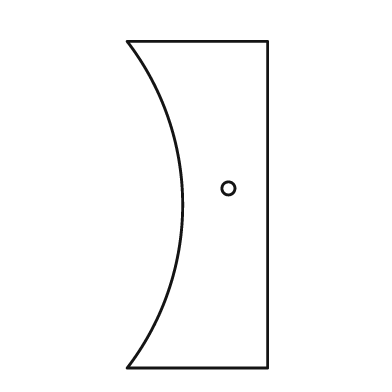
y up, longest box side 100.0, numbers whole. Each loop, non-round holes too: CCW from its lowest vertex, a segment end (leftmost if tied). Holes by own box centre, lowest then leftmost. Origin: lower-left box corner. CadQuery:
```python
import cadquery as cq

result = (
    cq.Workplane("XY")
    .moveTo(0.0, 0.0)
    .lineTo(43.0, 0.0)
    .lineTo(43.0, 100.0)
    .lineTo(0.0, 100.0)
    .threePointArc((17.0, 50.0), (0.0, 0.0))
    .close()
    .moveTo(31.0, 55.0)
    .circle(2.0)
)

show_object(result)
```